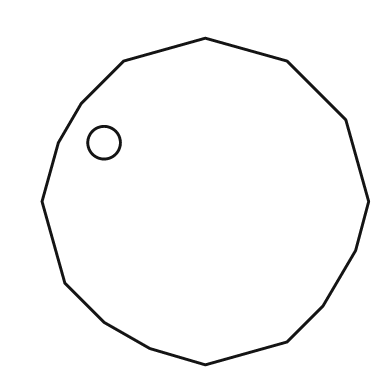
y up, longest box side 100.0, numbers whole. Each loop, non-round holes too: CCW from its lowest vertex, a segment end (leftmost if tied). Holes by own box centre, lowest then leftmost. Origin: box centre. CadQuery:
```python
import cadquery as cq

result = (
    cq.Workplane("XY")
    .moveTo(0.0, -50.0)
    .lineTo(25.0, -43.0)
    .lineTo(36.0, -32.0)
    .lineTo(46.0, -15.0)
    .lineTo(50.0, 0.0)
    .lineTo(43.0, 25.0)
    .lineTo(25.0, 43.0)
    .lineTo(0.0, 50.0)
    .lineTo(-25.0, 43.0)
    .lineTo(-38.0, 30.0)
    .lineTo(-45.0, 18.0)
    .lineTo(-50.0, 0.0)
    .lineTo(-43.0, -25.0)
    .lineTo(-31.0, -37.0)
    .lineTo(-17.0, -45.0)
    .close()
    .moveTo(-31.0, 18.0)
    .circle(5.0)
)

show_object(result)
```